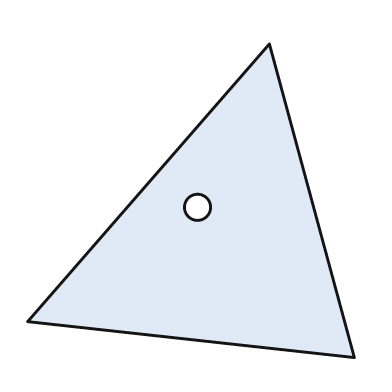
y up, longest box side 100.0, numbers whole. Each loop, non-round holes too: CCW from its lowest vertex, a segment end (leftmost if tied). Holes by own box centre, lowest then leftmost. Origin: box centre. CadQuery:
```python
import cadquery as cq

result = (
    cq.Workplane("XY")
    .moveTo(50.0, -48.0)
    .lineTo(24.0, 48.0)
    .lineTo(-50.0, -37.0)
    .close()
    .moveTo(2.0, -2.0)
    .circle(4.0)
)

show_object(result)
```